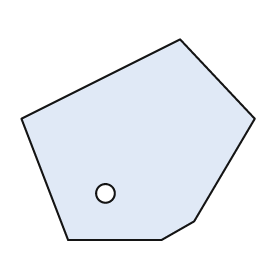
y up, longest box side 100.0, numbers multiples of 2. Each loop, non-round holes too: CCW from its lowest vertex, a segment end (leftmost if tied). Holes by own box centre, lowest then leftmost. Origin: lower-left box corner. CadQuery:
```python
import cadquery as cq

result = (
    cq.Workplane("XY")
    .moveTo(20.0, 0.0)
    .lineTo(60.0, 0.0)
    .lineTo(74.0, 8.0)
    .lineTo(100.0, 52.0)
    .lineTo(68.0, 86.0)
    .lineTo(0.0, 52.0)
    .close()
    .moveTo(36.0, 20.0)
    .circle(4.0)
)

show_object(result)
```